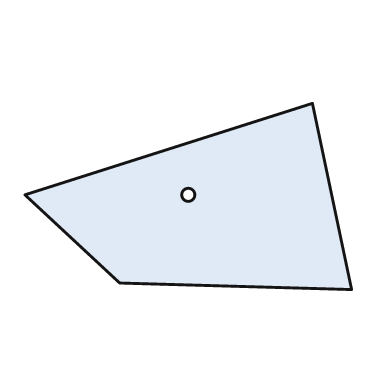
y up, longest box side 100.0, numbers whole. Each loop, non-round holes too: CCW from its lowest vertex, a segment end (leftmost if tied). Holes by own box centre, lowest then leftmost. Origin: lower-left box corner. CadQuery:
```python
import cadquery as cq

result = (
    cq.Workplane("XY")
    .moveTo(100.0, 0.0)
    .lineTo(88.0, 57.0)
    .lineTo(0.0, 29.0)
    .lineTo(29.0, 2.0)
    .close()
    .moveTo(50.0, 29.0)
    .circle(2.0)
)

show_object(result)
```